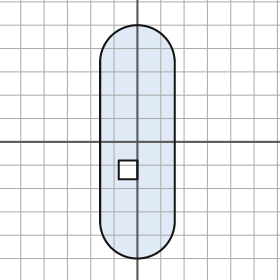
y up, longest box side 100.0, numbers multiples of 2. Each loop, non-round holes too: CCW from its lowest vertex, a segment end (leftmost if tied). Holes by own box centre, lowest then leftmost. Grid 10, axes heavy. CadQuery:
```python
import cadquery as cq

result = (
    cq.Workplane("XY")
    .moveTo(-16.0, -34.0)
    .threePointArc((0.0, -50.0), (16.0, -34.0))
    .lineTo(16.0, 34.0)
    .threePointArc((0.0, 50.0), (-16.0, 34.0))
    .close()
    .moveTo(-8.0, -16.0)
    .lineTo(0.0, -16.0)
    .lineTo(0.0, -8.0)
    .lineTo(-8.0, -8.0)
    .close()
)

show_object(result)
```